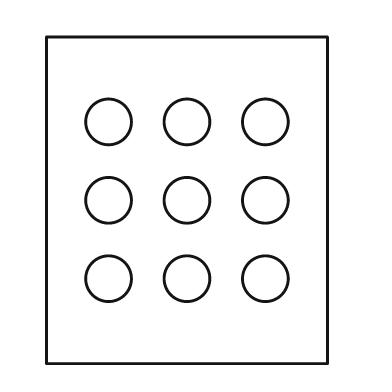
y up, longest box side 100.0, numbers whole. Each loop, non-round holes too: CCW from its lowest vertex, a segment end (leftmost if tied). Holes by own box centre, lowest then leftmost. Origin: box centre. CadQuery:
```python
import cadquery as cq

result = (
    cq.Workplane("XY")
    .moveTo(-43.0, -50.0)
    .lineTo(43.0, -50.0)
    .lineTo(43.0, 50.0)
    .lineTo(-43.0, 50.0)
    .close()
    .moveTo(-24.0, -24.0)
    .circle(7.0)
    .moveTo(0.0, -24.0)
    .circle(7.0)
    .moveTo(24.0, -24.0)
    .circle(7.0)
    .moveTo(-24.0, 0.0)
    .circle(7.0)
    .moveTo(0.0, 0.0)
    .circle(7.0)
    .moveTo(24.0, 0.0)
    .circle(7.0)
    .moveTo(-24.0, 24.0)
    .circle(7.0)
    .moveTo(0.0, 24.0)
    .circle(7.0)
    .moveTo(24.0, 24.0)
    .circle(7.0)
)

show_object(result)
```